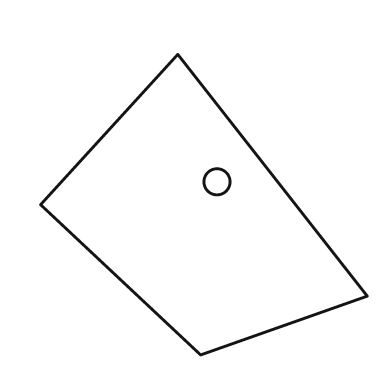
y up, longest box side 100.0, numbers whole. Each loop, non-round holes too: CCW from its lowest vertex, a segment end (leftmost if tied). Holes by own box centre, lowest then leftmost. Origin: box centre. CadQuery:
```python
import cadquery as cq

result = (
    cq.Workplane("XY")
    .moveTo(-1.0, -46.0)
    .lineTo(50.0, -28.0)
    .lineTo(-8.0, 46.0)
    .lineTo(-50.0, 0.0)
    .close()
    .moveTo(4.0, 7.0)
    .circle(4.0)
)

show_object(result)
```